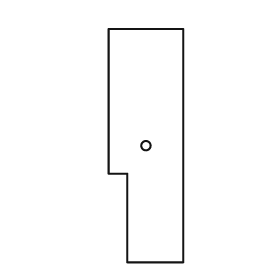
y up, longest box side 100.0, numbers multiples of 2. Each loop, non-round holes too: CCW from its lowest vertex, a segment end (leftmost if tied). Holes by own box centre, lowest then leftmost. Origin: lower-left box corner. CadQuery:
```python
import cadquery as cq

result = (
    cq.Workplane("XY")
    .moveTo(8.0, 0.0)
    .lineTo(32.0, 0.0)
    .lineTo(32.0, 100.0)
    .lineTo(0.0, 100.0)
    .lineTo(0.0, 38.0)
    .lineTo(8.0, 38.0)
    .close()
    .moveTo(16.0, 50.0)
    .circle(2.0)
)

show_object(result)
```